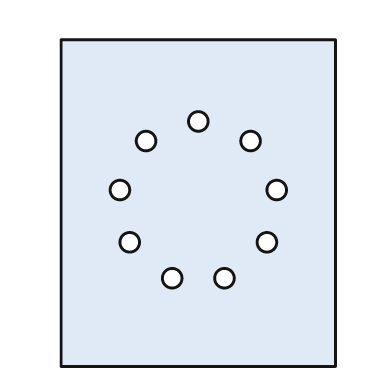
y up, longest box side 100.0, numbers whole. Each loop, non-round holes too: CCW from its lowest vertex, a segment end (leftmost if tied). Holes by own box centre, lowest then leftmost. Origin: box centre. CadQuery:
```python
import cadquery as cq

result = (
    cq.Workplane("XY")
    .moveTo(-42.0, -50.0)
    .lineTo(42.0, -50.0)
    .lineTo(42.0, 50.0)
    .lineTo(-42.0, 50.0)
    .close()
    .moveTo(-8.0, -23.0)
    .circle(3.0)
    .moveTo(8.0, -23.0)
    .circle(3.0)
    .moveTo(-21.0, -12.0)
    .circle(3.0)
    .moveTo(21.0, -12.0)
    .circle(3.0)
    .moveTo(-24.0, 4.0)
    .circle(3.0)
    .moveTo(24.0, 4.0)
    .circle(3.0)
    .moveTo(-16.0, 19.0)
    .circle(3.0)
    .moveTo(16.0, 19.0)
    .circle(3.0)
    .moveTo(0.0, 25.0)
    .circle(3.0)
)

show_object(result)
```